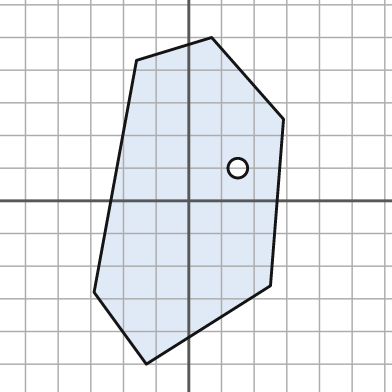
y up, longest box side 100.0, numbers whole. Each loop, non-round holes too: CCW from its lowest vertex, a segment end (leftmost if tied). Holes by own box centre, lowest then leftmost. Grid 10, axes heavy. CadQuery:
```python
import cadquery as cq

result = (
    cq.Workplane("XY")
    .moveTo(-13.0, -50.0)
    .lineTo(25.0, -26.0)
    .lineTo(29.0, 25.0)
    .lineTo(7.0, 50.0)
    .lineTo(-16.0, 43.0)
    .lineTo(-29.0, -28.0)
    .close()
    .moveTo(15.0, 10.0)
    .circle(3.0)
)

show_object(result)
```